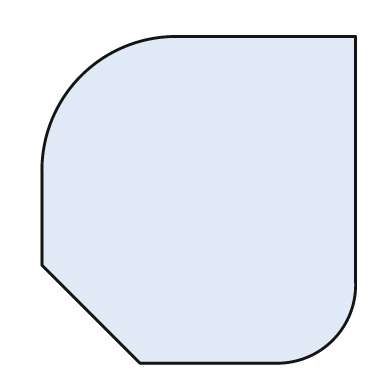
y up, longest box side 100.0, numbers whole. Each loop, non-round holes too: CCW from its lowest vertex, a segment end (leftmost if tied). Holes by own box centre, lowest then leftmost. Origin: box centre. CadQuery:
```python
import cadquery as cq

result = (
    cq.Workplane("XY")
    .moveTo(-18.0, -50.0)
    .lineTo(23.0, -50.0)
    .threePointArc((41.0, -43.0), (48.0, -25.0))
    .lineTo(48.0, 50.0)
    .lineTo(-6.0, 50.0)
    .threePointArc((-36.0, 38.0), (-48.0, 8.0))
    .lineTo(-48.0, -20.0)
    .close()
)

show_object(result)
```